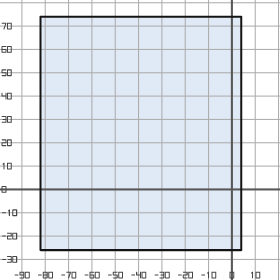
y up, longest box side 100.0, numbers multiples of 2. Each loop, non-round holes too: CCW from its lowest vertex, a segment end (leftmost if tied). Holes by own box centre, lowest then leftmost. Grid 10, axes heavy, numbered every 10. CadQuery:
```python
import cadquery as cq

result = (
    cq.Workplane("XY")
    .moveTo(-82.0, -26.0)
    .lineTo(4.0, -26.0)
    .lineTo(4.0, 74.0)
    .lineTo(-82.0, 74.0)
    .close()
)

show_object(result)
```